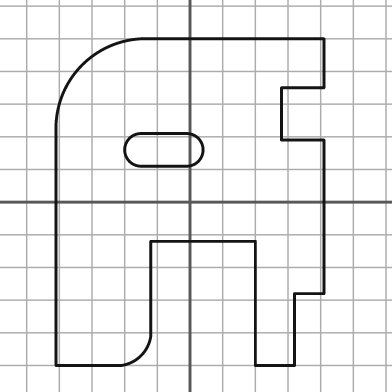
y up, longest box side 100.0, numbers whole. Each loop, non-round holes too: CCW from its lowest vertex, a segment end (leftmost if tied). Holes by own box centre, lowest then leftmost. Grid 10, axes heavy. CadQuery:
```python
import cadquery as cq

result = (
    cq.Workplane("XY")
    .moveTo(-41.0, -50.0)
    .lineTo(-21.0, -50.0)
    .threePointArc((-15.0, -47.0), (-12.0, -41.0))
    .lineTo(-12.0, -12.0)
    .lineTo(20.0, -12.0)
    .lineTo(20.0, -50.0)
    .lineTo(32.0, -50.0)
    .lineTo(32.0, -28.0)
    .lineTo(41.0, -28.0)
    .lineTo(41.0, 19.0)
    .lineTo(28.0, 19.0)
    .lineTo(28.0, 35.0)
    .lineTo(41.0, 35.0)
    .lineTo(41.0, 50.0)
    .lineTo(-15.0, 50.0)
    .threePointArc((-33.0, 42.0), (-41.0, 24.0))
    .close()
    .moveTo(-15.0, 11.0)
    .lineTo(-1.0, 11.0)
    .threePointArc((4.0, 16.0), (-1.0, 21.0))
    .lineTo(-15.0, 21.0)
    .threePointArc((-20.0, 16.0), (-15.0, 11.0))
    .close()
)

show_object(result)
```